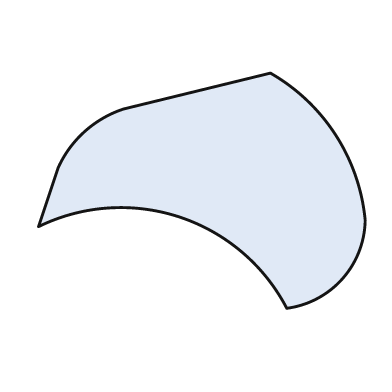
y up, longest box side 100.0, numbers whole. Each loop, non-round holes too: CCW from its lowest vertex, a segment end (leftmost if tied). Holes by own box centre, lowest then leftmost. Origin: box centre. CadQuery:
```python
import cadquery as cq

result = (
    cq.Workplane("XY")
    .moveTo(26.0, -36.0)
    .threePointArc((43.0, -27.0), (50.0, -9.0))
    .threePointArc((41.0, 17.0), (21.0, 36.0))
    .lineTo(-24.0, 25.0)
    .threePointArc((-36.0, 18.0), (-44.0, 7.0))
    .lineTo(-50.0, -11.0)
    .threePointArc((-7.0, -8.0), (26.0, -36.0))
    .close()
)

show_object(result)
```